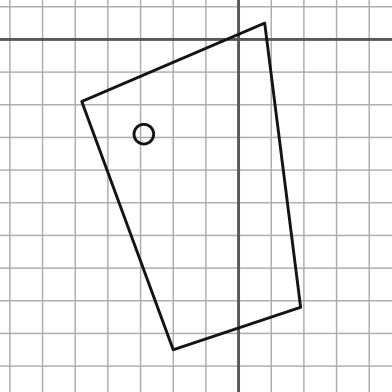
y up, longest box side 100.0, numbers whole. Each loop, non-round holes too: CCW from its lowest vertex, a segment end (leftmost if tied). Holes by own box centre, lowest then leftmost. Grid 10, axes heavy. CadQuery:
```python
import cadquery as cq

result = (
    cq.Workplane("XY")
    .moveTo(-20.0, -95.0)
    .lineTo(19.0, -82.0)
    .lineTo(8.0, 5.0)
    .lineTo(-48.0, -19.0)
    .close()
    .moveTo(-29.0, -29.0)
    .circle(3.0)
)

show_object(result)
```